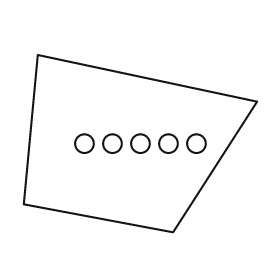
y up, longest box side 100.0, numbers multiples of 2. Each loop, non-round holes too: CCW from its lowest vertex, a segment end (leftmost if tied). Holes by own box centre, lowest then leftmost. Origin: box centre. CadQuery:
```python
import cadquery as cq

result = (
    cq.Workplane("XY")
    .moveTo(14.0, -38.0)
    .lineTo(50.0, 18.0)
    .lineTo(-44.0, 38.0)
    .lineTo(-50.0, -26.0)
    .close()
    .moveTo(-24.0, 0.0)
    .circle(4.0)
    .moveTo(-12.0, 0.0)
    .circle(4.0)
    .moveTo(0.0, 0.0)
    .circle(4.0)
    .moveTo(12.0, 0.0)
    .circle(4.0)
    .moveTo(24.0, 0.0)
    .circle(4.0)
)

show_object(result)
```